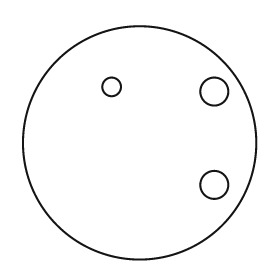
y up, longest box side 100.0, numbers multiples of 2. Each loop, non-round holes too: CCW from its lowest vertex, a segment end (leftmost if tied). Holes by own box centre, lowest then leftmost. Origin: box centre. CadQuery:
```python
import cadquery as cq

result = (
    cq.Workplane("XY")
    .moveTo(0.0, 0.0)
    .circle(50.0)
    .moveTo(32.0, -18.0)
    .circle(6.0)
    .moveTo(32.0, 22.0)
    .circle(6.0)
    .moveTo(-12.0, 24.0)
    .circle(4.0)
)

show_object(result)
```